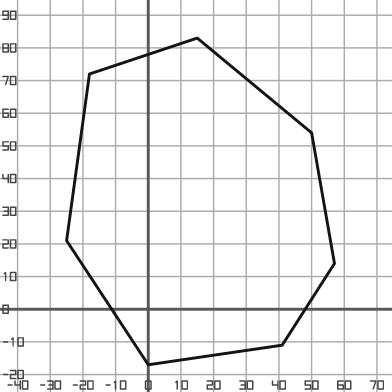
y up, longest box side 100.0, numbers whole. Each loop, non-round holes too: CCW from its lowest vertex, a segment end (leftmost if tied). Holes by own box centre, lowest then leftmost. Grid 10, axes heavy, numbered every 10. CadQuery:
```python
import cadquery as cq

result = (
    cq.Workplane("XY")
    .moveTo(0.0, -17.0)
    .lineTo(41.0, -11.0)
    .lineTo(57.0, 14.0)
    .lineTo(50.0, 54.0)
    .lineTo(15.0, 83.0)
    .lineTo(-18.0, 72.0)
    .lineTo(-25.0, 21.0)
    .close()
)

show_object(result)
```